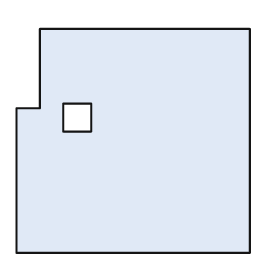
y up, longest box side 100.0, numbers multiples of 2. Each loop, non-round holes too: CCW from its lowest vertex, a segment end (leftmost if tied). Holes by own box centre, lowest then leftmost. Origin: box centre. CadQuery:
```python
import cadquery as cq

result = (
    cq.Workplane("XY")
    .moveTo(-50.0, -48.0)
    .lineTo(50.0, -48.0)
    .lineTo(50.0, 48.0)
    .lineTo(-40.0, 48.0)
    .lineTo(-40.0, 14.0)
    .lineTo(-50.0, 14.0)
    .close()
    .moveTo(-30.0, 4.0)
    .lineTo(-18.0, 4.0)
    .lineTo(-18.0, 16.0)
    .lineTo(-30.0, 16.0)
    .close()
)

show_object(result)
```